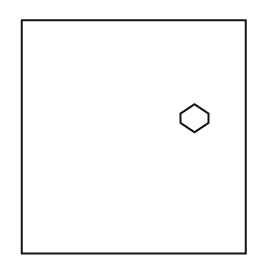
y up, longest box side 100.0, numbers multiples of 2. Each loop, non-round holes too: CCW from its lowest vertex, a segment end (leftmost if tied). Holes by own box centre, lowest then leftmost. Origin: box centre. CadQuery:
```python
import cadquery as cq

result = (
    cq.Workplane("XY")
    .moveTo(-48.0, -50.0)
    .lineTo(48.0, -50.0)
    .lineTo(48.0, 50.0)
    .lineTo(-48.0, 50.0)
    .close()
    .moveTo(26.0, 2.0)
    .lineTo(32.0, 6.0)
    .lineTo(32.0, 10.0)
    .lineTo(26.0, 14.0)
    .lineTo(20.0, 10.0)
    .lineTo(20.0, 6.0)
    .close()
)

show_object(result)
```